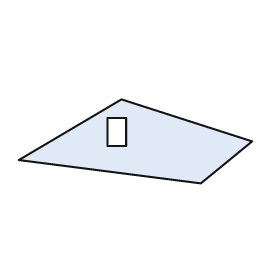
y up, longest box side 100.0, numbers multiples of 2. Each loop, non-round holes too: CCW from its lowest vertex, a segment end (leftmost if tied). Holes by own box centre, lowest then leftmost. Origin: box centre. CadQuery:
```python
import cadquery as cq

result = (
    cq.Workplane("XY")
    .moveTo(28.0, -18.0)
    .lineTo(50.0, 0.0)
    .lineTo(-6.0, 18.0)
    .lineTo(-50.0, -8.0)
    .close()
    .moveTo(-12.0, -2.0)
    .lineTo(-4.0, -2.0)
    .lineTo(-4.0, 10.0)
    .lineTo(-12.0, 10.0)
    .close()
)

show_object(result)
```